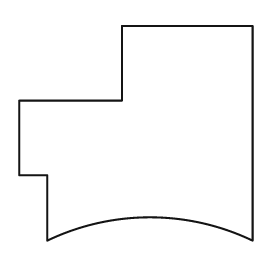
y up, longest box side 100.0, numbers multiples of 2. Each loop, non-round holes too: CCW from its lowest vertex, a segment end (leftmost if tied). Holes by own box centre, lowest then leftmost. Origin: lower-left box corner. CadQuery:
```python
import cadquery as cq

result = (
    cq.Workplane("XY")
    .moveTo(12.0, 0.0)
    .threePointArc((56.0, 10.0), (100.0, 0.0))
    .lineTo(100.0, 92.0)
    .lineTo(44.0, 92.0)
    .lineTo(44.0, 60.0)
    .lineTo(0.0, 60.0)
    .lineTo(0.0, 28.0)
    .lineTo(12.0, 28.0)
    .close()
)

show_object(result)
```